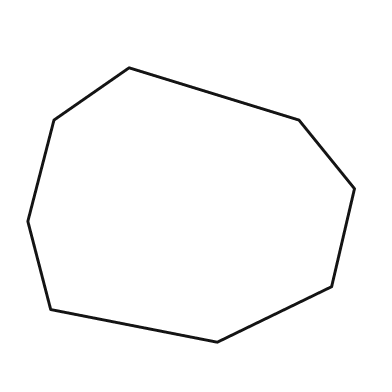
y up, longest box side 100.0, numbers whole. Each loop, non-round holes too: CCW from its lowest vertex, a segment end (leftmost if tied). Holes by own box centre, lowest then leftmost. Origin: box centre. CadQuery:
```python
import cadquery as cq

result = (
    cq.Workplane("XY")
    .moveTo(8.0, -42.0)
    .lineTo(43.0, -25.0)
    .lineTo(50.0, 5.0)
    .lineTo(33.0, 26.0)
    .lineTo(-19.0, 42.0)
    .lineTo(-42.0, 26.0)
    .lineTo(-50.0, -5.0)
    .lineTo(-43.0, -32.0)
    .close()
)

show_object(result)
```